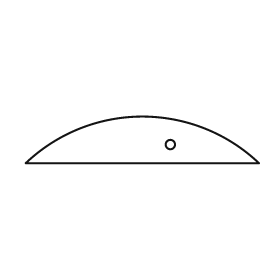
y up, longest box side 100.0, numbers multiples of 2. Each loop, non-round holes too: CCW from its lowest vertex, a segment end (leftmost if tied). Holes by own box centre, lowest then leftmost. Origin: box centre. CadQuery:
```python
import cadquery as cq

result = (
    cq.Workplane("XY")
    .moveTo(-50.0, -10.0)
    .lineTo(50.0, -10.0)
    .threePointArc((0.0, 10.0), (-50.0, -10.0))
    .close()
    .moveTo(12.0, -2.0)
    .circle(2.0)
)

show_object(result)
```